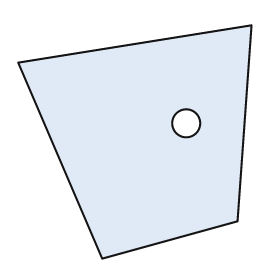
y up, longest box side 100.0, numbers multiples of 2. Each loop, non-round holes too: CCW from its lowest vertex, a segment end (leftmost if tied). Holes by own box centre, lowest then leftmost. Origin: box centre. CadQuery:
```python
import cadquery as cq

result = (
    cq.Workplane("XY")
    .moveTo(-14.0, -50.0)
    .lineTo(44.0, -34.0)
    .lineTo(50.0, 50.0)
    .lineTo(-50.0, 34.0)
    .close()
    .moveTo(22.0, 8.0)
    .circle(6.0)
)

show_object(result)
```